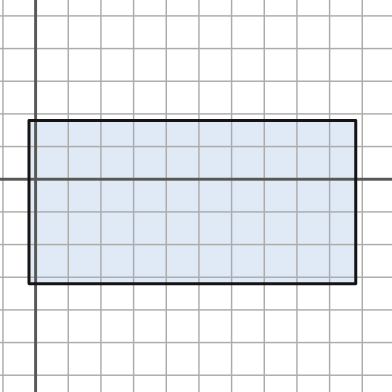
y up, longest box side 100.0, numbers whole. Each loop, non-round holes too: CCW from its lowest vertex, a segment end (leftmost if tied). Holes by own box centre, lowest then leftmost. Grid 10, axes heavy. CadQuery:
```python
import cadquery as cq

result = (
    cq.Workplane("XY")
    .moveTo(-2.0, -32.0)
    .lineTo(98.0, -32.0)
    .lineTo(98.0, 18.0)
    .lineTo(-2.0, 18.0)
    .close()
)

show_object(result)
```